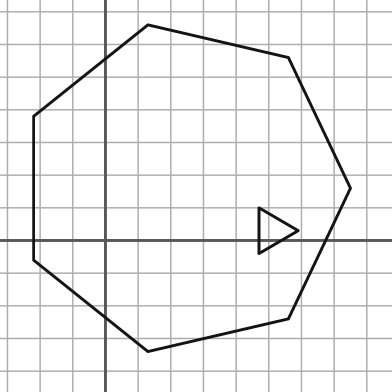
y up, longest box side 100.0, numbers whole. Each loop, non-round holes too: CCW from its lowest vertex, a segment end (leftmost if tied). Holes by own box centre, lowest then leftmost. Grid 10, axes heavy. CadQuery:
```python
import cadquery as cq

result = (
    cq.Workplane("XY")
    .moveTo(13.0, -34.0)
    .lineTo(56.0, -24.0)
    .lineTo(75.0, 16.0)
    .lineTo(56.0, 56.0)
    .lineTo(13.0, 66.0)
    .lineTo(-22.0, 38.0)
    .lineTo(-22.0, -6.0)
    .close()
    .moveTo(47.0, -4.0)
    .lineTo(59.0, 3.0)
    .lineTo(47.0, 10.0)
    .close()
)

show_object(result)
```